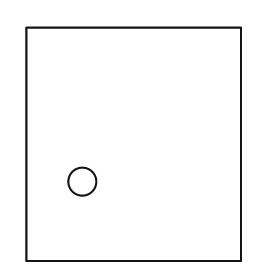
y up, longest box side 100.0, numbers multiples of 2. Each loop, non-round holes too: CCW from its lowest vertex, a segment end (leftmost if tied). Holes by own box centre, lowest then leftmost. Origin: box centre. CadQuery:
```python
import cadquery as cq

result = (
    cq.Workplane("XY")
    .moveTo(-46.0, -50.0)
    .lineTo(46.0, -50.0)
    .lineTo(46.0, 50.0)
    .lineTo(-46.0, 50.0)
    .close()
    .moveTo(-22.0, -16.0)
    .circle(6.0)
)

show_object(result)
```